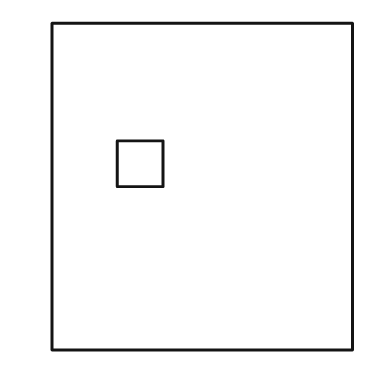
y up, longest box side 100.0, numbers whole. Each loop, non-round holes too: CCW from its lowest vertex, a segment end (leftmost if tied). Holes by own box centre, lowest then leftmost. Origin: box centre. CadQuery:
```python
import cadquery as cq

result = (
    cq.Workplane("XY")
    .moveTo(-46.0, -50.0)
    .lineTo(46.0, -50.0)
    .lineTo(46.0, 50.0)
    .lineTo(-46.0, 50.0)
    .close()
    .moveTo(-26.0, 0.0)
    .lineTo(-12.0, 0.0)
    .lineTo(-12.0, 14.0)
    .lineTo(-26.0, 14.0)
    .close()
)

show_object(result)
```